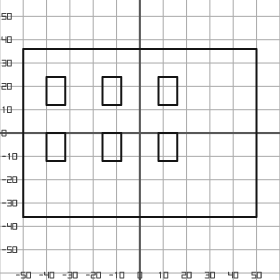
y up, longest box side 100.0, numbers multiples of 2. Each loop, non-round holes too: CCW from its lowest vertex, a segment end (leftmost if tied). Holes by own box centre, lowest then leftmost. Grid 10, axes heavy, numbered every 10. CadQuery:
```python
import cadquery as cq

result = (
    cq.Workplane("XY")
    .moveTo(-50.0, -36.0)
    .lineTo(50.0, -36.0)
    .lineTo(50.0, 36.0)
    .lineTo(-50.0, 36.0)
    .close()
    .moveTo(-40.0, -12.0)
    .lineTo(-32.0, -12.0)
    .lineTo(-32.0, 0.0)
    .lineTo(-40.0, 0.0)
    .close()
    .moveTo(-16.0, -12.0)
    .lineTo(-8.0, -12.0)
    .lineTo(-8.0, 0.0)
    .lineTo(-16.0, 0.0)
    .close()
    .moveTo(8.0, -12.0)
    .lineTo(16.0, -12.0)
    .lineTo(16.0, 0.0)
    .lineTo(8.0, 0.0)
    .close()
    .moveTo(-40.0, 12.0)
    .lineTo(-32.0, 12.0)
    .lineTo(-32.0, 24.0)
    .lineTo(-40.0, 24.0)
    .close()
    .moveTo(-16.0, 12.0)
    .lineTo(-8.0, 12.0)
    .lineTo(-8.0, 24.0)
    .lineTo(-16.0, 24.0)
    .close()
    .moveTo(8.0, 12.0)
    .lineTo(16.0, 12.0)
    .lineTo(16.0, 24.0)
    .lineTo(8.0, 24.0)
    .close()
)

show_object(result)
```